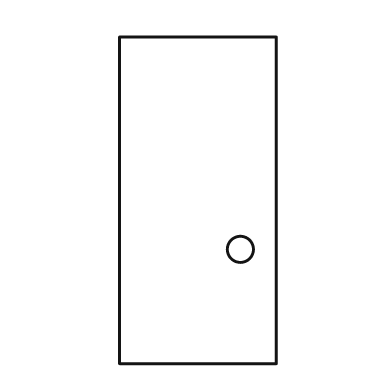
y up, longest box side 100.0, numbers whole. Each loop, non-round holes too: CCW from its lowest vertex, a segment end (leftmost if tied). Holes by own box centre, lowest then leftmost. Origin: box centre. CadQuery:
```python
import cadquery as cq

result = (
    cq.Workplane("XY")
    .moveTo(-24.0, -50.0)
    .lineTo(24.0, -50.0)
    .lineTo(24.0, 50.0)
    .lineTo(-24.0, 50.0)
    .close()
    .moveTo(13.0, -15.0)
    .circle(4.0)
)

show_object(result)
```